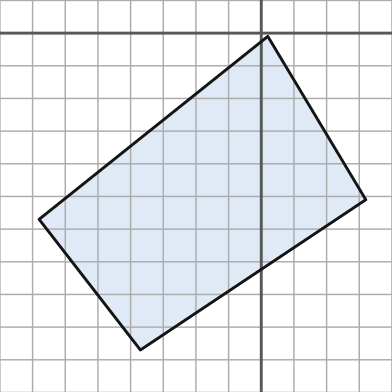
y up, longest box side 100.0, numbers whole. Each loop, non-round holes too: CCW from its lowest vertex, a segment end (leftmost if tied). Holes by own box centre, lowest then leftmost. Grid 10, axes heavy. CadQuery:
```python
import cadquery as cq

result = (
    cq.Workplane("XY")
    .moveTo(-37.0, -97.0)
    .lineTo(32.0, -51.0)
    .lineTo(2.0, -1.0)
    .lineTo(-68.0, -57.0)
    .close()
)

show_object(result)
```